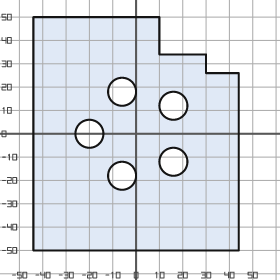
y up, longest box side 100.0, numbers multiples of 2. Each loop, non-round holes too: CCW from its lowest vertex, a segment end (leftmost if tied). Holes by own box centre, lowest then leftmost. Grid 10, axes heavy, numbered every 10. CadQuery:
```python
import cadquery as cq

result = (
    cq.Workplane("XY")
    .moveTo(-44.0, -50.0)
    .lineTo(44.0, -50.0)
    .lineTo(44.0, 26.0)
    .lineTo(30.0, 26.0)
    .lineTo(30.0, 34.0)
    .lineTo(10.0, 34.0)
    .lineTo(10.0, 50.0)
    .lineTo(-44.0, 50.0)
    .close()
    .moveTo(-6.0, -18.0)
    .circle(6.0)
    .moveTo(16.0, -12.0)
    .circle(6.0)
    .moveTo(-20.0, 0.0)
    .circle(6.0)
    .moveTo(16.0, 12.0)
    .circle(6.0)
    .moveTo(-6.0, 18.0)
    .circle(6.0)
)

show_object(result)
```